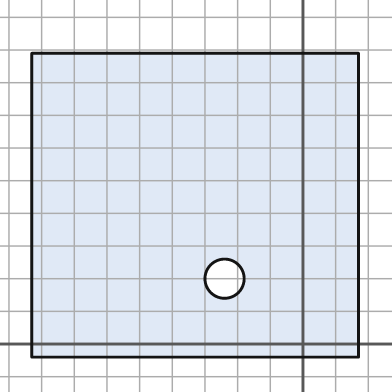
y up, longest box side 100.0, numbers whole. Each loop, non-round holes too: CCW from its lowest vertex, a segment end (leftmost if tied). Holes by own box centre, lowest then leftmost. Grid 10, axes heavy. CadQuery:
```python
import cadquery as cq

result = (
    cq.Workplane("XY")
    .moveTo(-83.0, -4.0)
    .lineTo(17.0, -4.0)
    .lineTo(17.0, 89.0)
    .lineTo(-83.0, 89.0)
    .close()
    .moveTo(-24.0, 20.0)
    .circle(6.0)
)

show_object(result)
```